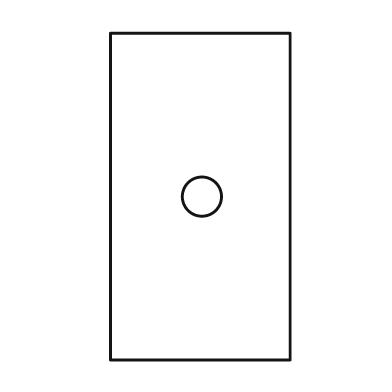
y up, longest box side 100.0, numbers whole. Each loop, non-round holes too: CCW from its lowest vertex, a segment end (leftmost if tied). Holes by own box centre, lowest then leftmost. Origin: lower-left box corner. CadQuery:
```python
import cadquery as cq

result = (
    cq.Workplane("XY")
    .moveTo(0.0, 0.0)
    .lineTo(55.0, 0.0)
    .lineTo(55.0, 100.0)
    .lineTo(0.0, 100.0)
    .close()
    .moveTo(28.0, 50.0)
    .circle(6.0)
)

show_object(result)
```